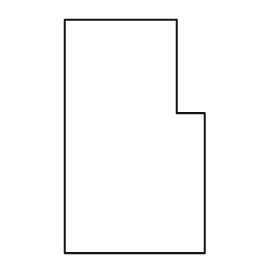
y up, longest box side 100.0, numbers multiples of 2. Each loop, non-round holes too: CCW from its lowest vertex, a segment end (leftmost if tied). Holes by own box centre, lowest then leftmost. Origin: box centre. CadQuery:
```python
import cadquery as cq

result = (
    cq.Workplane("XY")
    .moveTo(-30.0, -50.0)
    .lineTo(30.0, -50.0)
    .lineTo(30.0, 10.0)
    .lineTo(18.0, 10.0)
    .lineTo(18.0, 50.0)
    .lineTo(-30.0, 50.0)
    .close()
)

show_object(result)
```